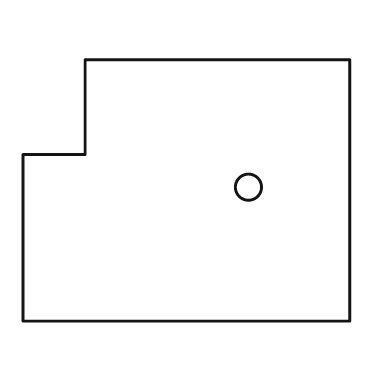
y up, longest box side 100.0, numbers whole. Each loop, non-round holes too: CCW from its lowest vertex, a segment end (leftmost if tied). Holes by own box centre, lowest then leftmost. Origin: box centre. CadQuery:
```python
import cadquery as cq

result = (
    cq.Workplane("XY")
    .moveTo(-50.0, -40.0)
    .lineTo(50.0, -40.0)
    .lineTo(50.0, 40.0)
    .lineTo(-31.0, 40.0)
    .lineTo(-31.0, 11.0)
    .lineTo(-50.0, 11.0)
    .close()
    .moveTo(19.0, 1.0)
    .circle(4.0)
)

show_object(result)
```